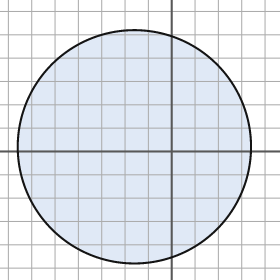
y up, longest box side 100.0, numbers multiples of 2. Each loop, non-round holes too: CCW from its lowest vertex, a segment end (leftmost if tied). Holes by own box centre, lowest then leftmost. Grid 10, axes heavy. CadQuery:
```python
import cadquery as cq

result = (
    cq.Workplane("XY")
    .moveTo(-16.0, 2.0)
    .circle(50.0)
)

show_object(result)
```